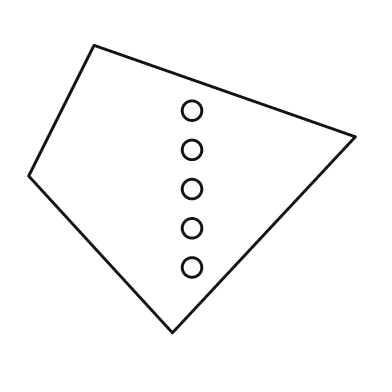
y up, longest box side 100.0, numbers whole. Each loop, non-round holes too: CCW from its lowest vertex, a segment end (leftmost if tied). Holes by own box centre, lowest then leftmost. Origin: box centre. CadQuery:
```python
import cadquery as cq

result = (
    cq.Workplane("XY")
    .moveTo(-6.0, -44.0)
    .lineTo(50.0, 16.0)
    .lineTo(-30.0, 44.0)
    .lineTo(-50.0, 4.0)
    .close()
    .moveTo(0.0, -24.0)
    .circle(3.0)
    .moveTo(0.0, -12.0)
    .circle(3.0)
    .moveTo(0.0, 0.0)
    .circle(3.0)
    .moveTo(0.0, 12.0)
    .circle(3.0)
    .moveTo(0.0, 24.0)
    .circle(3.0)
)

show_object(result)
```